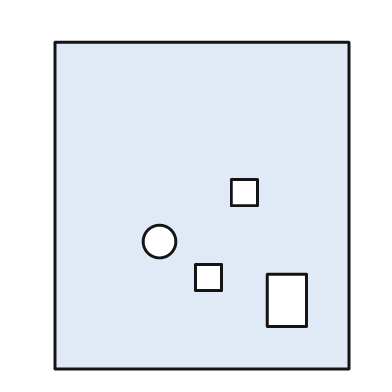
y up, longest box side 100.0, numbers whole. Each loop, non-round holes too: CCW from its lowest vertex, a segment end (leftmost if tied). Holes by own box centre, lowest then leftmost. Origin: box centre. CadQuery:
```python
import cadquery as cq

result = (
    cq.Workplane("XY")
    .moveTo(-45.0, -50.0)
    .lineTo(45.0, -50.0)
    .lineTo(45.0, 50.0)
    .lineTo(-45.0, 50.0)
    .close()
    .moveTo(20.0, -37.0)
    .lineTo(32.0, -37.0)
    .lineTo(32.0, -21.0)
    .lineTo(20.0, -21.0)
    .close()
    .moveTo(-2.0, -26.0)
    .lineTo(6.0, -26.0)
    .lineTo(6.0, -18.0)
    .lineTo(-2.0, -18.0)
    .close()
    .moveTo(-13.0, -11.0)
    .circle(5.0)
    .moveTo(9.0, 0.0)
    .lineTo(17.0, 0.0)
    .lineTo(17.0, 8.0)
    .lineTo(9.0, 8.0)
    .close()
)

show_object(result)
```